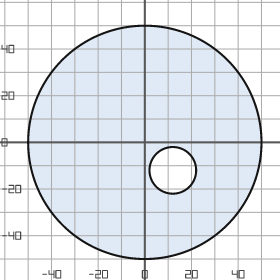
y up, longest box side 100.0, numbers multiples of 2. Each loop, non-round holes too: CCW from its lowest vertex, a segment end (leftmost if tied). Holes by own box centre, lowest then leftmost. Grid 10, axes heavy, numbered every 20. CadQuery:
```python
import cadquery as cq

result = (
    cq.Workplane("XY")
    .moveTo(0.0, 0.0)
    .circle(50.0)
    .moveTo(12.0, -12.0)
    .circle(10.0)
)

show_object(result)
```